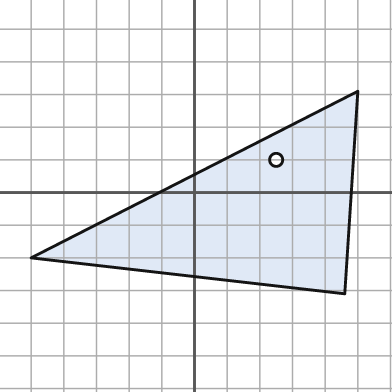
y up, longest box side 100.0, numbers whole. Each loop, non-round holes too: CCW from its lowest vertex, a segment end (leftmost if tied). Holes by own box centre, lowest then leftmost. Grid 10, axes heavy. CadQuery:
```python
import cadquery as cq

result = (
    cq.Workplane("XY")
    .moveTo(46.0, -31.0)
    .lineTo(50.0, 31.0)
    .lineTo(-50.0, -20.0)
    .close()
    .moveTo(25.0, 10.0)
    .circle(2.0)
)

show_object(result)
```